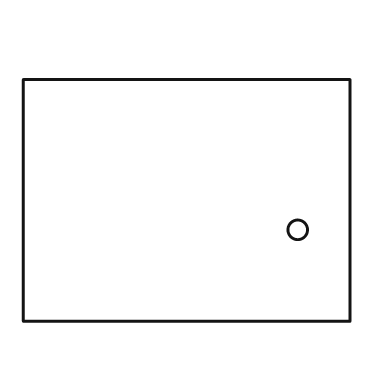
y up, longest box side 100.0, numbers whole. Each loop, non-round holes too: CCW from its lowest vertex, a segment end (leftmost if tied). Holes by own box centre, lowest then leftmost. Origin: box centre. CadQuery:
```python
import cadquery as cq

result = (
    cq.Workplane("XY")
    .moveTo(-50.0, -37.0)
    .lineTo(50.0, -37.0)
    .lineTo(50.0, 37.0)
    .lineTo(-50.0, 37.0)
    .close()
    .moveTo(34.0, -9.0)
    .circle(3.0)
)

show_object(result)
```